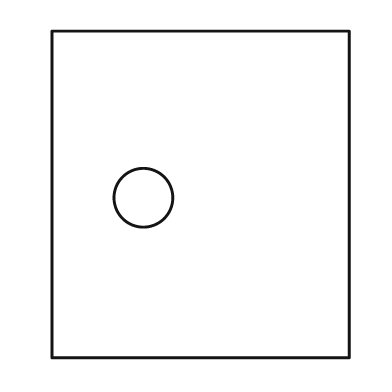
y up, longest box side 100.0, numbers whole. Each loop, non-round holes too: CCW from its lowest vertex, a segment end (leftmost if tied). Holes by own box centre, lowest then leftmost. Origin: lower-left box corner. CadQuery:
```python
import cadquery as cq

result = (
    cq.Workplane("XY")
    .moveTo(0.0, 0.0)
    .lineTo(91.0, 0.0)
    .lineTo(91.0, 100.0)
    .lineTo(0.0, 100.0)
    .close()
    .moveTo(28.0, 49.0)
    .circle(9.0)
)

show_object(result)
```